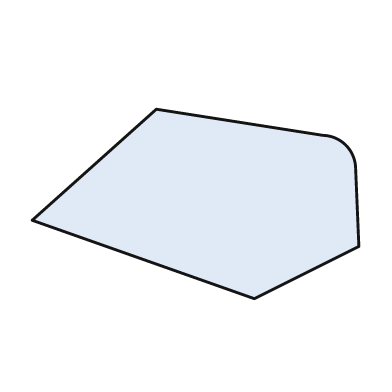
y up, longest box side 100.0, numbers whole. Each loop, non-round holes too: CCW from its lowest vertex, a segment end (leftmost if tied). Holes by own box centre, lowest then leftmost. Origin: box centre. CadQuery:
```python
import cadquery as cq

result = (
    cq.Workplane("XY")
    .moveTo(18.0, -29.0)
    .lineTo(50.0, -13.0)
    .lineTo(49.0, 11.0)
    .threePointArc((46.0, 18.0), (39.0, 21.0))
    .lineTo(-12.0, 29.0)
    .lineTo(-50.0, -5.0)
    .close()
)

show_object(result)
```